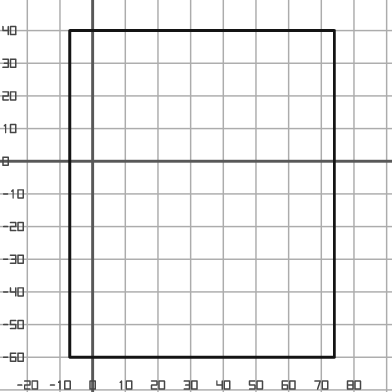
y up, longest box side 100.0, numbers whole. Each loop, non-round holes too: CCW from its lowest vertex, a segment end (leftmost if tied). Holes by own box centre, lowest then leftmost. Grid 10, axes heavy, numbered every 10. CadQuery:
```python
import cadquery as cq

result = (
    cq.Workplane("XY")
    .moveTo(-7.0, -60.0)
    .lineTo(74.0, -60.0)
    .lineTo(74.0, 40.0)
    .lineTo(-7.0, 40.0)
    .close()
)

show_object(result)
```